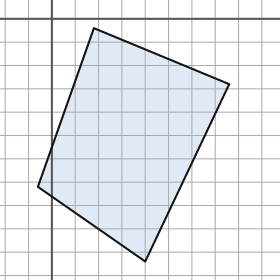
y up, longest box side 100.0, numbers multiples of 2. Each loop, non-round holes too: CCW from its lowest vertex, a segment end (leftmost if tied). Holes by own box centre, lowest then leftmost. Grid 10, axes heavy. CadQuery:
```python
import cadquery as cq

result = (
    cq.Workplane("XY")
    .moveTo(40.0, -104.0)
    .lineTo(76.0, -28.0)
    .lineTo(18.0, -4.0)
    .lineTo(-6.0, -72.0)
    .close()
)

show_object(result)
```